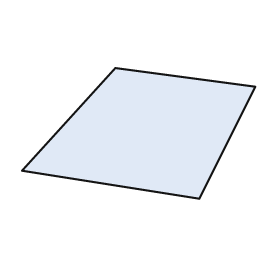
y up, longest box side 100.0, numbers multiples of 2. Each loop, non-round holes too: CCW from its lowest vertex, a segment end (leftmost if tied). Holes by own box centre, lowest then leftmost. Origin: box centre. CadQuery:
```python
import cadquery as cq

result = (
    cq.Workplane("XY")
    .moveTo(26.0, -28.0)
    .lineTo(50.0, 20.0)
    .lineTo(-10.0, 28.0)
    .lineTo(-50.0, -16.0)
    .close()
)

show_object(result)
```